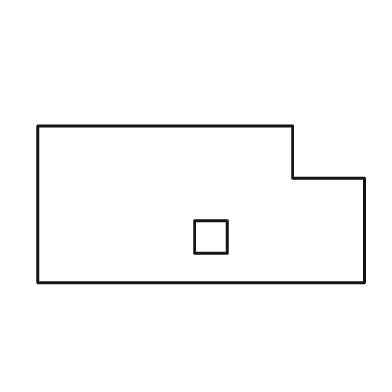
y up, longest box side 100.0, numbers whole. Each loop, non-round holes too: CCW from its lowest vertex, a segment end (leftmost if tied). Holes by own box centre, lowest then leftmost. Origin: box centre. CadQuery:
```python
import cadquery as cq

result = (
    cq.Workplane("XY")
    .moveTo(-50.0, -24.0)
    .lineTo(50.0, -24.0)
    .lineTo(50.0, 8.0)
    .lineTo(28.0, 8.0)
    .lineTo(28.0, 24.0)
    .lineTo(-50.0, 24.0)
    .close()
    .moveTo(-2.0, -15.0)
    .lineTo(8.0, -15.0)
    .lineTo(8.0, -5.0)
    .lineTo(-2.0, -5.0)
    .close()
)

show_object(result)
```